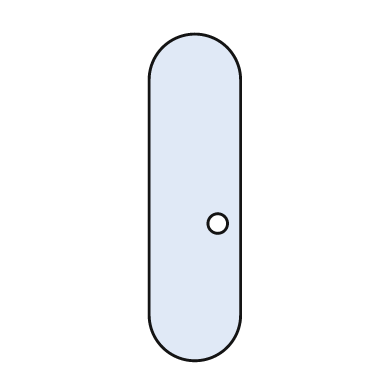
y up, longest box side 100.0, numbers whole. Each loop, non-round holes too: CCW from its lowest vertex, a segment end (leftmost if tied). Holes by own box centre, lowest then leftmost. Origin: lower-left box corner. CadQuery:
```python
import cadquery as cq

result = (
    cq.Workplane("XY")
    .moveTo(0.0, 14.0)
    .threePointArc((14.0, 0.0), (28.0, 14.0))
    .lineTo(28.0, 86.0)
    .threePointArc((14.0, 100.0), (0.0, 86.0))
    .close()
    .moveTo(21.0, 42.0)
    .circle(3.0)
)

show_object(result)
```